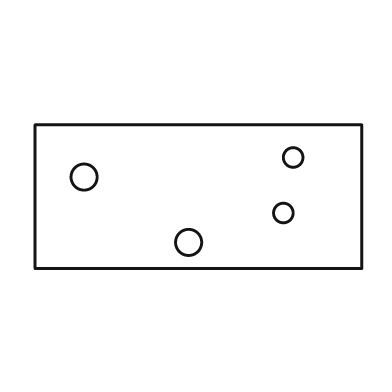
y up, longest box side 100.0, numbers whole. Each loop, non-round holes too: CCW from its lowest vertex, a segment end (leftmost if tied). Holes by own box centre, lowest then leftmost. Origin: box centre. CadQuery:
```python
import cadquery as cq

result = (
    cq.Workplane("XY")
    .moveTo(-50.0, -22.0)
    .lineTo(50.0, -22.0)
    .lineTo(50.0, 22.0)
    .lineTo(-50.0, 22.0)
    .close()
    .moveTo(-3.0, -14.0)
    .circle(4.0)
    .moveTo(26.0, -5.0)
    .circle(3.0)
    .moveTo(-35.0, 6.0)
    .circle(4.0)
    .moveTo(29.0, 12.0)
    .circle(3.0)
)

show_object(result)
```